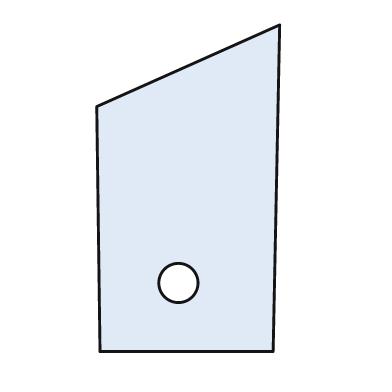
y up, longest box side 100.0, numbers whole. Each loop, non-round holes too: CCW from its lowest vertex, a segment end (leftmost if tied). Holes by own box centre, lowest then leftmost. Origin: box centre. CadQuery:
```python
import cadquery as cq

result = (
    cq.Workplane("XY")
    .moveTo(-27.0, -50.0)
    .lineTo(26.0, -50.0)
    .lineTo(28.0, 50.0)
    .lineTo(-28.0, 25.0)
    .close()
    .moveTo(-3.0, -29.0)
    .circle(6.0)
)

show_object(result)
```